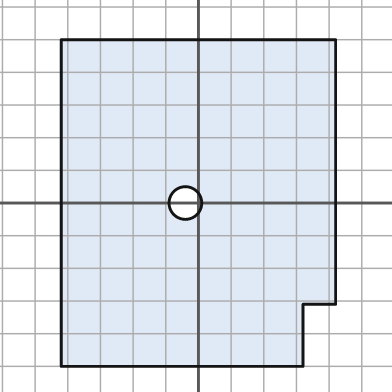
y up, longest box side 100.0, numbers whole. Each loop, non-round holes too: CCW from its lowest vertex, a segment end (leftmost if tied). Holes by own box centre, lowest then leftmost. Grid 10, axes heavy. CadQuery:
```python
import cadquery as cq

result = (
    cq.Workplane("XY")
    .moveTo(-42.0, -50.0)
    .lineTo(32.0, -50.0)
    .lineTo(32.0, -31.0)
    .lineTo(42.0, -31.0)
    .lineTo(42.0, 50.0)
    .lineTo(-42.0, 50.0)
    .close()
    .moveTo(-4.0, 0.0)
    .circle(5.0)
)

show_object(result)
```